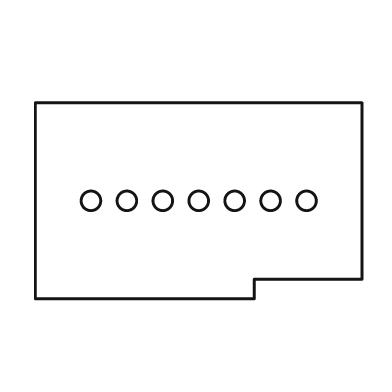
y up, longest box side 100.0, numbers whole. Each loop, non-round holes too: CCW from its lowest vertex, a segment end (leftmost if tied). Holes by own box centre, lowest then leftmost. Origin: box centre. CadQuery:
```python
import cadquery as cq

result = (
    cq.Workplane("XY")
    .moveTo(-50.0, -30.0)
    .lineTo(17.0, -30.0)
    .lineTo(17.0, -24.0)
    .lineTo(50.0, -24.0)
    .lineTo(50.0, 30.0)
    .lineTo(-50.0, 30.0)
    .close()
    .moveTo(-33.0, 0.0)
    .circle(3.0)
    .moveTo(-22.0, 0.0)
    .circle(3.0)
    .moveTo(-11.0, 0.0)
    .circle(3.0)
    .moveTo(0.0, 0.0)
    .circle(3.0)
    .moveTo(11.0, 0.0)
    .circle(3.0)
    .moveTo(22.0, 0.0)
    .circle(3.0)
    .moveTo(33.0, 0.0)
    .circle(3.0)
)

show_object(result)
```